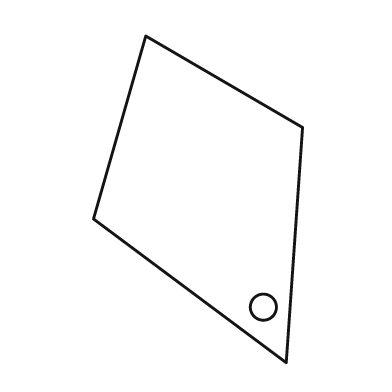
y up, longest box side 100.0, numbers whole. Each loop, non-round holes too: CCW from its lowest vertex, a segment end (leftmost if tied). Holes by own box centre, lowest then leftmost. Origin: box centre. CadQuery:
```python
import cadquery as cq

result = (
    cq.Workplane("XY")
    .moveTo(27.0, -50.0)
    .lineTo(32.0, 22.0)
    .lineTo(-16.0, 50.0)
    .lineTo(-32.0, -6.0)
    .close()
    .moveTo(20.0, -33.0)
    .circle(4.0)
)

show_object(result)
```